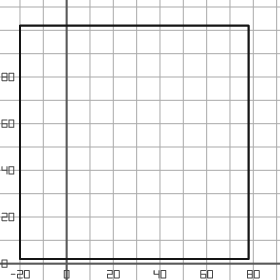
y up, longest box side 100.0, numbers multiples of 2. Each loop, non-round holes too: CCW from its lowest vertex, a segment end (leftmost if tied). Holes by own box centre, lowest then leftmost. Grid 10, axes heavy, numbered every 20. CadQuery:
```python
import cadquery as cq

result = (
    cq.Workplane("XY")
    .moveTo(-20.0, 2.0)
    .lineTo(78.0, 2.0)
    .lineTo(78.0, 102.0)
    .lineTo(-20.0, 102.0)
    .close()
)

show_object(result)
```